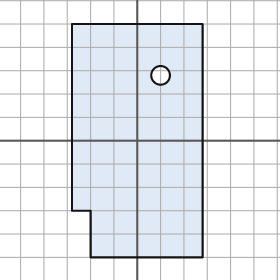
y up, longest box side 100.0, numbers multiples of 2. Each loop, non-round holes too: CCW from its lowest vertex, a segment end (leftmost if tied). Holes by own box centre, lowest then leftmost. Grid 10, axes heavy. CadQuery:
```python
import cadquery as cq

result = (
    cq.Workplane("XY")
    .moveTo(-20.0, -50.0)
    .lineTo(28.0, -50.0)
    .lineTo(28.0, 50.0)
    .lineTo(-28.0, 50.0)
    .lineTo(-28.0, -30.0)
    .lineTo(-20.0, -30.0)
    .close()
    .moveTo(10.0, 28.0)
    .circle(4.0)
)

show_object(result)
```